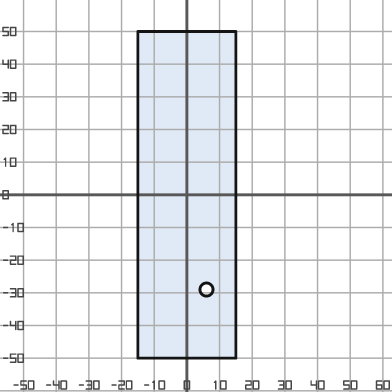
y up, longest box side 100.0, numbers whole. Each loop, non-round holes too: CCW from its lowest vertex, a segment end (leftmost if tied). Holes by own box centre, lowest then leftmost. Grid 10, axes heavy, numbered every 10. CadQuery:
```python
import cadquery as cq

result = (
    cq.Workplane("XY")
    .moveTo(-15.0, -50.0)
    .lineTo(15.0, -50.0)
    .lineTo(15.0, 50.0)
    .lineTo(-15.0, 50.0)
    .close()
    .moveTo(6.0, -29.0)
    .circle(2.0)
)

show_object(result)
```